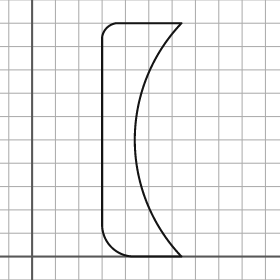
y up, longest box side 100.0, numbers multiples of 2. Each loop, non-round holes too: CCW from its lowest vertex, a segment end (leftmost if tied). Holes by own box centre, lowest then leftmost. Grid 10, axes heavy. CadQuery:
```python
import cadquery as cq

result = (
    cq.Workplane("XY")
    .moveTo(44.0, 0.0)
    .lineTo(64.0, 0.0)
    .threePointArc((44.0, 50.0), (64.0, 100.0))
    .lineTo(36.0, 100.0)
    .threePointArc((32.0, 98.0), (30.0, 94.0))
    .lineTo(30.0, 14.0)
    .threePointArc((34.0, 4.0), (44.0, 0.0))
    .close()
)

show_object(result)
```